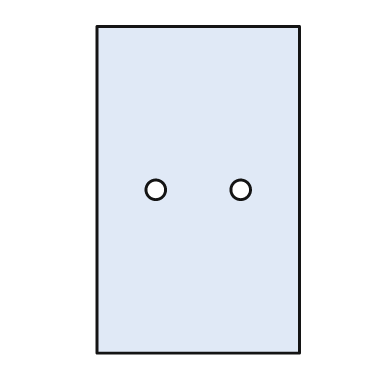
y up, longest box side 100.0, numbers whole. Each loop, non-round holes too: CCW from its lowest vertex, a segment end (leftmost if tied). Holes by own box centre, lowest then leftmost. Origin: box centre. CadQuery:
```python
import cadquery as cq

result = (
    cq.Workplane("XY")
    .moveTo(-31.0, -50.0)
    .lineTo(31.0, -50.0)
    .lineTo(31.0, 50.0)
    .lineTo(-31.0, 50.0)
    .close()
    .moveTo(-13.0, 0.0)
    .circle(3.0)
    .moveTo(13.0, 0.0)
    .circle(3.0)
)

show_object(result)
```